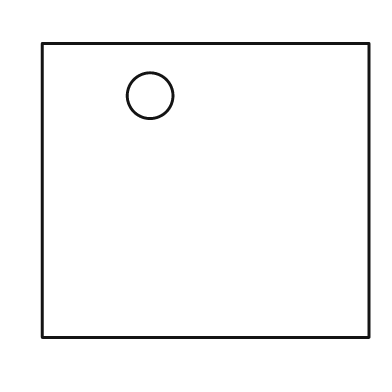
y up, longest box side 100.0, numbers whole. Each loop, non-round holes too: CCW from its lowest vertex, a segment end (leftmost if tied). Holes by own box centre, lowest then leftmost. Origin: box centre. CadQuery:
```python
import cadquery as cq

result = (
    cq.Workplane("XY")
    .moveTo(-50.0, -45.0)
    .lineTo(50.0, -45.0)
    .lineTo(50.0, 45.0)
    .lineTo(-50.0, 45.0)
    .close()
    .moveTo(-17.0, 29.0)
    .circle(7.0)
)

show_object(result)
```